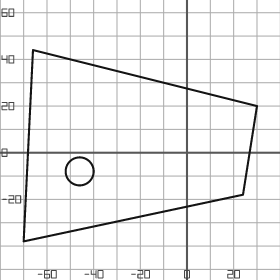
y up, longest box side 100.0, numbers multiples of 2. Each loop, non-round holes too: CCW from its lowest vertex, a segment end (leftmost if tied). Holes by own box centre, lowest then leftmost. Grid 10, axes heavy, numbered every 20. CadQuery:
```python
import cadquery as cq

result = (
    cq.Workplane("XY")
    .moveTo(-70.0, -38.0)
    .lineTo(24.0, -18.0)
    .lineTo(30.0, 20.0)
    .lineTo(-66.0, 44.0)
    .close()
    .moveTo(-46.0, -8.0)
    .circle(6.0)
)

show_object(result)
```